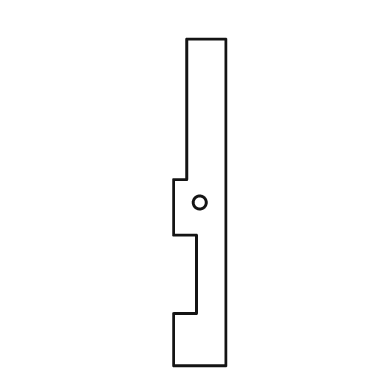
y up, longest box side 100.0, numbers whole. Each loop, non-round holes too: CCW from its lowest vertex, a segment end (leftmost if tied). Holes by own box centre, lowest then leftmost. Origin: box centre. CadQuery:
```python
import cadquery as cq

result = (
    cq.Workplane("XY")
    .moveTo(-8.0, -50.0)
    .lineTo(8.0, -50.0)
    .lineTo(8.0, 50.0)
    .lineTo(-4.0, 50.0)
    .lineTo(-4.0, 7.0)
    .lineTo(-8.0, 7.0)
    .lineTo(-8.0, -10.0)
    .lineTo(-1.0, -10.0)
    .lineTo(-1.0, -34.0)
    .lineTo(-8.0, -34.0)
    .close()
    .moveTo(0.0, 0.0)
    .circle(2.0)
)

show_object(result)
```